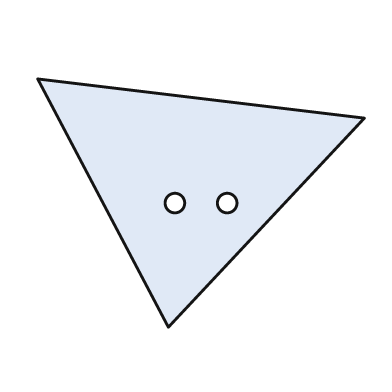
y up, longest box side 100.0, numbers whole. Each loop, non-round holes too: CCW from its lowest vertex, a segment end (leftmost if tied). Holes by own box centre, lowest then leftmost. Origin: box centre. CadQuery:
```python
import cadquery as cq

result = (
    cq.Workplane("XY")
    .moveTo(-10.0, -38.0)
    .lineTo(50.0, 26.0)
    .lineTo(-50.0, 38.0)
    .close()
    .moveTo(-8.0, 0.0)
    .circle(3.0)
    .moveTo(8.0, 0.0)
    .circle(3.0)
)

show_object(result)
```